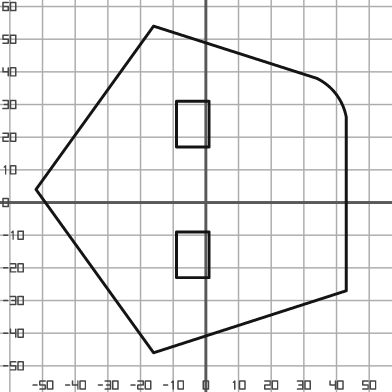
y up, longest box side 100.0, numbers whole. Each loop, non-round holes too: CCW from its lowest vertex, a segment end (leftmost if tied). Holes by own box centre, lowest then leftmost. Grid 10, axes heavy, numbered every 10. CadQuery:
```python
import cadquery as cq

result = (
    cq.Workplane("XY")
    .moveTo(-16.0, -46.0)
    .lineTo(43.0, -27.0)
    .lineTo(43.0, 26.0)
    .threePointArc((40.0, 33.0), (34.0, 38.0))
    .lineTo(-16.0, 54.0)
    .lineTo(-52.0, 4.0)
    .close()
    .moveTo(-9.0, -23.0)
    .lineTo(1.0, -23.0)
    .lineTo(1.0, -9.0)
    .lineTo(-9.0, -9.0)
    .close()
    .moveTo(-9.0, 17.0)
    .lineTo(1.0, 17.0)
    .lineTo(1.0, 31.0)
    .lineTo(-9.0, 31.0)
    .close()
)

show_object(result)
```